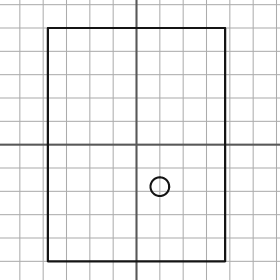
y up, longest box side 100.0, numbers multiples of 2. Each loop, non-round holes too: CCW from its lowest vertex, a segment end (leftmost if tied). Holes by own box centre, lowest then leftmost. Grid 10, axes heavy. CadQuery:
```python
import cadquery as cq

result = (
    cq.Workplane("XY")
    .moveTo(-38.0, -50.0)
    .lineTo(38.0, -50.0)
    .lineTo(38.0, 50.0)
    .lineTo(-38.0, 50.0)
    .close()
    .moveTo(10.0, -18.0)
    .circle(4.0)
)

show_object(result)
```